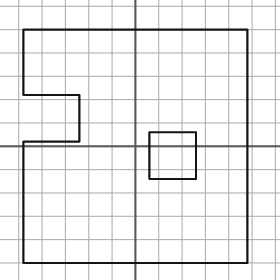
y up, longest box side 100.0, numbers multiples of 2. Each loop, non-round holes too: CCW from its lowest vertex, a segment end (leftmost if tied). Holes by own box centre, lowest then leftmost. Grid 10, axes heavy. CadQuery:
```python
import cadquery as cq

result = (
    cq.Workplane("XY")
    .moveTo(-48.0, -50.0)
    .lineTo(48.0, -50.0)
    .lineTo(48.0, 50.0)
    .lineTo(-48.0, 50.0)
    .lineTo(-48.0, 22.0)
    .lineTo(-24.0, 22.0)
    .lineTo(-24.0, 2.0)
    .lineTo(-48.0, 2.0)
    .close()
    .moveTo(6.0, -14.0)
    .lineTo(26.0, -14.0)
    .lineTo(26.0, 6.0)
    .lineTo(6.0, 6.0)
    .close()
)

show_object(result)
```